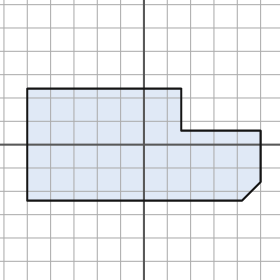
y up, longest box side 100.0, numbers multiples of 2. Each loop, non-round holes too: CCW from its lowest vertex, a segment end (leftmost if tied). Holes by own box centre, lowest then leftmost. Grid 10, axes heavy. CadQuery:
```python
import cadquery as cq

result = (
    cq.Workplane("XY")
    .moveTo(-50.0, -24.0)
    .lineTo(42.0, -24.0)
    .lineTo(50.0, -16.0)
    .lineTo(50.0, 6.0)
    .lineTo(16.0, 6.0)
    .lineTo(16.0, 24.0)
    .lineTo(-50.0, 24.0)
    .close()
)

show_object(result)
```